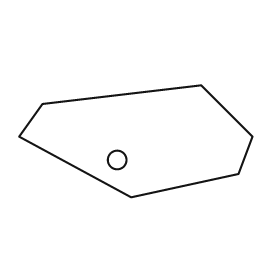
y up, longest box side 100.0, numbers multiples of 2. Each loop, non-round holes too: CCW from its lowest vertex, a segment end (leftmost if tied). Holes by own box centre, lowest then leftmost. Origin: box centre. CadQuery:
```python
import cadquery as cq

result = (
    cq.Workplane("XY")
    .moveTo(-2.0, -24.0)
    .lineTo(44.0, -14.0)
    .lineTo(50.0, 2.0)
    .lineTo(28.0, 24.0)
    .lineTo(-40.0, 16.0)
    .lineTo(-50.0, 2.0)
    .close()
    .moveTo(-8.0, -8.0)
    .circle(4.0)
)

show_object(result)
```